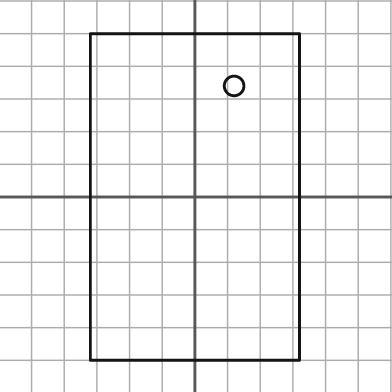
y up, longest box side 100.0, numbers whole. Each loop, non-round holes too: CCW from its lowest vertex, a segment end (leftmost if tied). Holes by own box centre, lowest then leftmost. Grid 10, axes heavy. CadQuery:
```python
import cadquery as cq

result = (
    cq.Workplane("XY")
    .moveTo(-32.0, -50.0)
    .lineTo(32.0, -50.0)
    .lineTo(32.0, 50.0)
    .lineTo(-32.0, 50.0)
    .close()
    .moveTo(12.0, 34.0)
    .circle(3.0)
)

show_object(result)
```